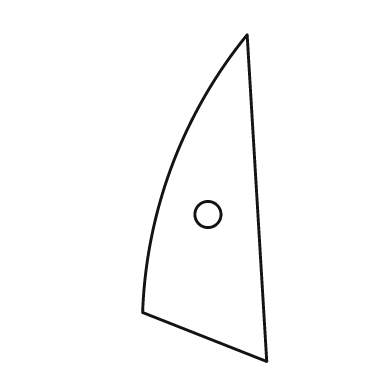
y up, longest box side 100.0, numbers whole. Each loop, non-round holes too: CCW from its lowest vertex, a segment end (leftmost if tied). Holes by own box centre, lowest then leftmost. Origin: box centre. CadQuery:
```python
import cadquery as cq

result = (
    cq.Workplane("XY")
    .moveTo(19.0, -50.0)
    .lineTo(13.0, 50.0)
    .threePointArc((-10.0, 10.0), (-19.0, -35.0))
    .close()
    .moveTo(1.0, -5.0)
    .circle(4.0)
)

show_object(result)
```